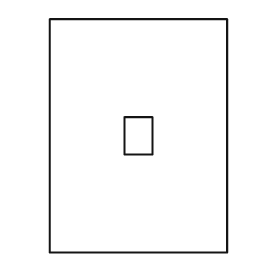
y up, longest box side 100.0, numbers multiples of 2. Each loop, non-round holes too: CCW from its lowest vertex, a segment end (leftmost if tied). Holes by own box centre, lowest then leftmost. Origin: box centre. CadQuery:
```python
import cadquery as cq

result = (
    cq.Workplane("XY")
    .moveTo(-38.0, -50.0)
    .lineTo(38.0, -50.0)
    .lineTo(38.0, 50.0)
    .lineTo(-38.0, 50.0)
    .close()
    .moveTo(-6.0, -8.0)
    .lineTo(6.0, -8.0)
    .lineTo(6.0, 8.0)
    .lineTo(-6.0, 8.0)
    .close()
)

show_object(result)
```